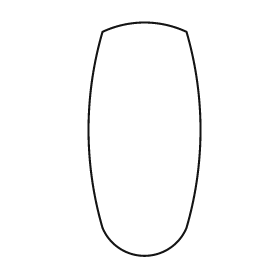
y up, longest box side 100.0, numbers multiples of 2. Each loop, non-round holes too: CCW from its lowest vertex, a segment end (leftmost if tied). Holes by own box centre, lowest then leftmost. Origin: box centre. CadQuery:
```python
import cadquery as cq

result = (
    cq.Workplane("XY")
    .moveTo(-18.0, -38.0)
    .threePointArc((0.0, -50.0), (18.0, -38.0))
    .threePointArc((24.0, 4.0), (18.0, 46.0))
    .threePointArc((0.0, 50.0), (-18.0, 46.0))
    .threePointArc((-24.0, 4.0), (-18.0, -38.0))
    .close()
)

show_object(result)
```